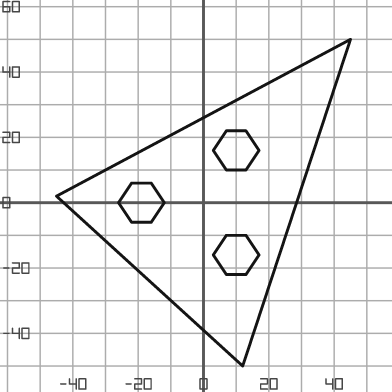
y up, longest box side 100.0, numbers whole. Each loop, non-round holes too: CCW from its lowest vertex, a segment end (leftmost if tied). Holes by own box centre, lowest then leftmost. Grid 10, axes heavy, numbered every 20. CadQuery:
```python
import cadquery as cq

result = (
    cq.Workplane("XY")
    .moveTo(12.0, -50.0)
    .lineTo(45.0, 50.0)
    .lineTo(-45.0, 2.0)
    .close()
    .moveTo(7.0, -22.0)
    .lineTo(13.0, -22.0)
    .lineTo(17.0, -16.0)
    .lineTo(13.0, -10.0)
    .lineTo(7.0, -10.0)
    .lineTo(3.0, -16.0)
    .close()
    .moveTo(-22.0, -6.0)
    .lineTo(-16.0, -6.0)
    .lineTo(-12.0, 0.0)
    .lineTo(-16.0, 6.0)
    .lineTo(-22.0, 6.0)
    .lineTo(-26.0, 0.0)
    .close()
    .moveTo(7.0, 10.0)
    .lineTo(13.0, 10.0)
    .lineTo(17.0, 16.0)
    .lineTo(13.0, 22.0)
    .lineTo(7.0, 22.0)
    .lineTo(3.0, 16.0)
    .close()
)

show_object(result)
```